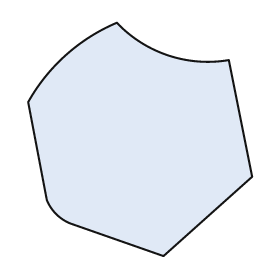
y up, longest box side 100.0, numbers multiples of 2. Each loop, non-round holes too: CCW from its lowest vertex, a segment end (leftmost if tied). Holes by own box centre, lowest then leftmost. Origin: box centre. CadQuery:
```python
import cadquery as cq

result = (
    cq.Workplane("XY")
    .moveTo(10.0, -50.0)
    .lineTo(48.0, -16.0)
    .lineTo(38.0, 34.0)
    .threePointArc((12.0, 36.0), (-10.0, 50.0))
    .threePointArc((-32.0, 36.0), (-48.0, 16.0))
    .lineTo(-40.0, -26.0)
    .threePointArc((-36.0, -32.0), (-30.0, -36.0))
    .close()
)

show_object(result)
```